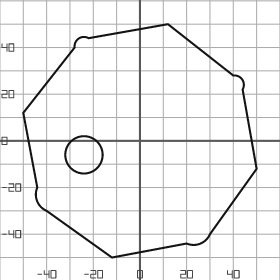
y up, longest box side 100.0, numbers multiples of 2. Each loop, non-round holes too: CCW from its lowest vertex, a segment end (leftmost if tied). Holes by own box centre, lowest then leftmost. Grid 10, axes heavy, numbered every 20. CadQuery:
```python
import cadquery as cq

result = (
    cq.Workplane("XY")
    .moveTo(-12.0, -50.0)
    .lineTo(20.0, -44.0)
    .threePointArc((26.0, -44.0), (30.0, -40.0))
    .lineTo(50.0, -12.0)
    .lineTo(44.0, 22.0)
    .threePointArc((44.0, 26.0), (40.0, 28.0))
    .lineTo(12.0, 50.0)
    .lineTo(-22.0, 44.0)
    .threePointArc((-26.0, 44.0), (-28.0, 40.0))
    .lineTo(-50.0, 12.0)
    .lineTo(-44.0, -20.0)
    .threePointArc((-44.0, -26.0), (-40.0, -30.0))
    .close()
    .moveTo(-24.0, -6.0)
    .circle(8.0)
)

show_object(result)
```